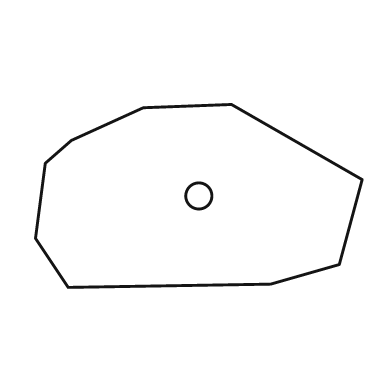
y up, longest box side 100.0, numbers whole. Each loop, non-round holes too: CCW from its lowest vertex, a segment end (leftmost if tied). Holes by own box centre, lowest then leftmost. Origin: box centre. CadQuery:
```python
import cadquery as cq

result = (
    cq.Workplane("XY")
    .moveTo(-40.0, -28.0)
    .lineTo(22.0, -27.0)
    .lineTo(43.0, -21.0)
    .lineTo(50.0, 5.0)
    .lineTo(10.0, 28.0)
    .lineTo(-17.0, 27.0)
    .lineTo(-39.0, 17.0)
    .lineTo(-47.0, 10.0)
    .lineTo(-50.0, -13.0)
    .close()
    .moveTo(0.0, 0.0)
    .circle(4.0)
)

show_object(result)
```